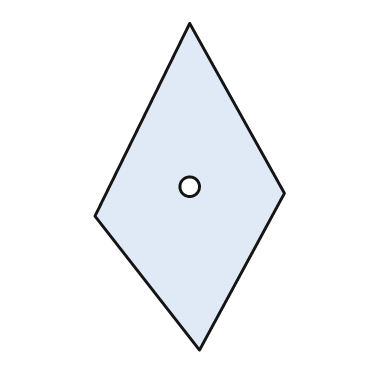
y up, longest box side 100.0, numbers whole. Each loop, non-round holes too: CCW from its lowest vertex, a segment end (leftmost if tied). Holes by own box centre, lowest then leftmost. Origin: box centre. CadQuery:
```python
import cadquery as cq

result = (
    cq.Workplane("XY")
    .moveTo(3.0, -50.0)
    .lineTo(29.0, -2.0)
    .lineTo(0.0, 50.0)
    .lineTo(-29.0, -9.0)
    .close()
    .moveTo(0.0, 0.0)
    .circle(3.0)
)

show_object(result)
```